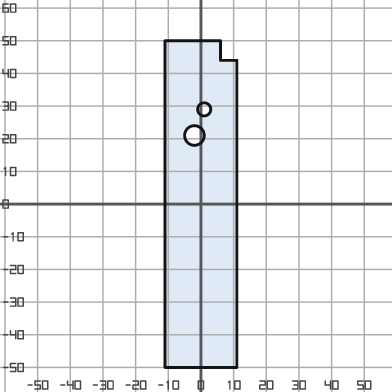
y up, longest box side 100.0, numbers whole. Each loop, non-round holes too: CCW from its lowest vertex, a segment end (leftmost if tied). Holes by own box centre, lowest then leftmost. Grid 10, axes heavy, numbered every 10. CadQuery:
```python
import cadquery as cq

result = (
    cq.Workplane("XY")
    .moveTo(-11.0, -50.0)
    .lineTo(11.0, -50.0)
    .lineTo(11.0, 44.0)
    .lineTo(6.0, 44.0)
    .lineTo(6.0, 50.0)
    .lineTo(-11.0, 50.0)
    .close()
    .moveTo(-2.0, 21.0)
    .circle(3.0)
    .moveTo(1.0, 29.0)
    .circle(2.0)
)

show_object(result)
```